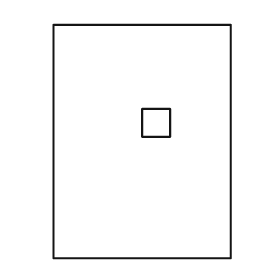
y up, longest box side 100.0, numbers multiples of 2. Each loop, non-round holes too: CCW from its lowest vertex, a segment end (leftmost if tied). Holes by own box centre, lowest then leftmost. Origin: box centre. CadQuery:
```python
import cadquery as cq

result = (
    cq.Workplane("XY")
    .moveTo(-38.0, -50.0)
    .lineTo(38.0, -50.0)
    .lineTo(38.0, 50.0)
    .lineTo(-38.0, 50.0)
    .close()
    .moveTo(0.0, 2.0)
    .lineTo(12.0, 2.0)
    .lineTo(12.0, 14.0)
    .lineTo(0.0, 14.0)
    .close()
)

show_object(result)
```